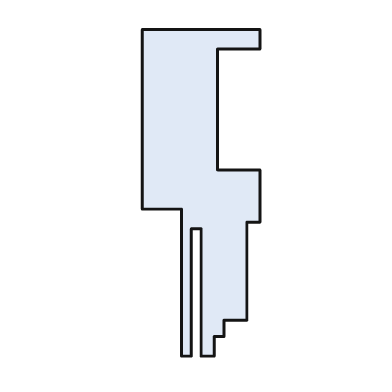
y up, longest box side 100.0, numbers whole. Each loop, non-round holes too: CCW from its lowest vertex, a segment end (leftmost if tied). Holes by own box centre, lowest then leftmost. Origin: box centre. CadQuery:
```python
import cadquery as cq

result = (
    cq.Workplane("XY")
    .moveTo(-6.0, -50.0)
    .lineTo(-3.0, -50.0)
    .lineTo(-3.0, -11.0)
    .lineTo(0.0, -11.0)
    .lineTo(0.0, -50.0)
    .lineTo(4.0, -50.0)
    .lineTo(4.0, -44.0)
    .lineTo(7.0, -44.0)
    .lineTo(7.0, -39.0)
    .lineTo(14.0, -39.0)
    .lineTo(14.0, -9.0)
    .lineTo(18.0, -9.0)
    .lineTo(18.0, 7.0)
    .lineTo(5.0, 7.0)
    .lineTo(5.0, 44.0)
    .lineTo(18.0, 44.0)
    .lineTo(18.0, 50.0)
    .lineTo(-18.0, 50.0)
    .lineTo(-18.0, -5.0)
    .lineTo(-6.0, -5.0)
    .close()
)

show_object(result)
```